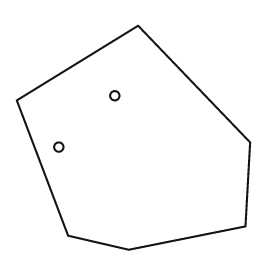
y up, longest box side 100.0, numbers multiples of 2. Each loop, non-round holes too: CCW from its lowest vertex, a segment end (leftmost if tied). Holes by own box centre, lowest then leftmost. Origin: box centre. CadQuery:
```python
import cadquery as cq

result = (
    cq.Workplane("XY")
    .moveTo(-2.0, -48.0)
    .lineTo(48.0, -38.0)
    .lineTo(50.0, -2.0)
    .lineTo(2.0, 48.0)
    .lineTo(-50.0, 16.0)
    .lineTo(-28.0, -42.0)
    .close()
    .moveTo(-32.0, -4.0)
    .circle(2.0)
    .moveTo(-8.0, 18.0)
    .circle(2.0)
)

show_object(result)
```